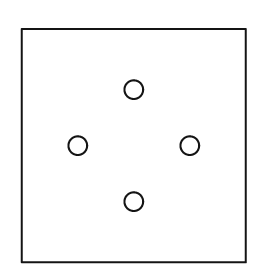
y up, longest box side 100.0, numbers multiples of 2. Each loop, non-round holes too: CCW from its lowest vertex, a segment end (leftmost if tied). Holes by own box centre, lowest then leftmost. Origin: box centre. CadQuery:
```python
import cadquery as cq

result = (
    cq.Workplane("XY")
    .moveTo(-48.0, -50.0)
    .lineTo(48.0, -50.0)
    .lineTo(48.0, 50.0)
    .lineTo(-48.0, 50.0)
    .close()
    .moveTo(0.0, -24.0)
    .circle(4.0)
    .moveTo(-24.0, 0.0)
    .circle(4.0)
    .moveTo(24.0, 0.0)
    .circle(4.0)
    .moveTo(0.0, 24.0)
    .circle(4.0)
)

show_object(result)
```